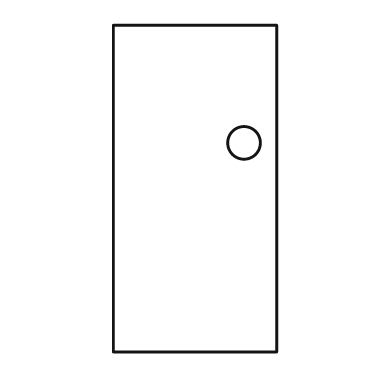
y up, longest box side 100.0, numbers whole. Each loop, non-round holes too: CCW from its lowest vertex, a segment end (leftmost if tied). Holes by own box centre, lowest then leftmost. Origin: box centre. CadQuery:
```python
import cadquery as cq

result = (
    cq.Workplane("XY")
    .moveTo(-25.0, -50.0)
    .lineTo(25.0, -50.0)
    .lineTo(25.0, 50.0)
    .lineTo(-25.0, 50.0)
    .close()
    .moveTo(15.0, 14.0)
    .circle(5.0)
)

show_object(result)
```